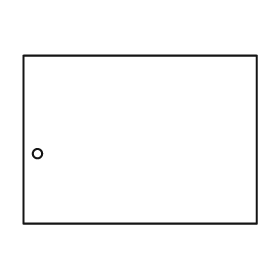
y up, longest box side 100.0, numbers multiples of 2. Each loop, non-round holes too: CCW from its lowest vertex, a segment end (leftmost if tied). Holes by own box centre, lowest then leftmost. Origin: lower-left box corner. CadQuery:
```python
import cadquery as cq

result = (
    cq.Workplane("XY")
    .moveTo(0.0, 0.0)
    .lineTo(100.0, 0.0)
    .lineTo(100.0, 72.0)
    .lineTo(0.0, 72.0)
    .close()
    .moveTo(6.0, 30.0)
    .circle(2.0)
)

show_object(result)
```